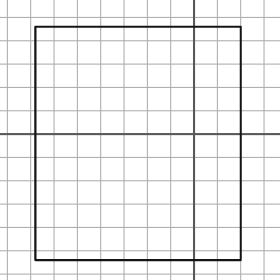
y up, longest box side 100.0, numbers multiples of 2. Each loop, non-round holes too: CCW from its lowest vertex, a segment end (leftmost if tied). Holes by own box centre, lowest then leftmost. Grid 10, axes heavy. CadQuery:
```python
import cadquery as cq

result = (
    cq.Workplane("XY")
    .moveTo(-68.0, -54.0)
    .lineTo(20.0, -54.0)
    .lineTo(20.0, 46.0)
    .lineTo(-68.0, 46.0)
    .close()
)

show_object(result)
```